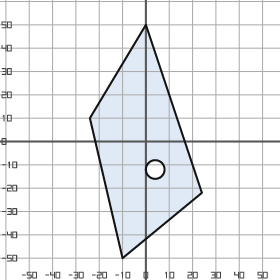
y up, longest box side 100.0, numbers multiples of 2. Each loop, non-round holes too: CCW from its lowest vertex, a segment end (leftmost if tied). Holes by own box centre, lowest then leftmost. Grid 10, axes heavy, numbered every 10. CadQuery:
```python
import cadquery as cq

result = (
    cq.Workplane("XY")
    .moveTo(-10.0, -50.0)
    .lineTo(24.0, -22.0)
    .lineTo(0.0, 50.0)
    .lineTo(-24.0, 10.0)
    .close()
    .moveTo(4.0, -12.0)
    .circle(4.0)
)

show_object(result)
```